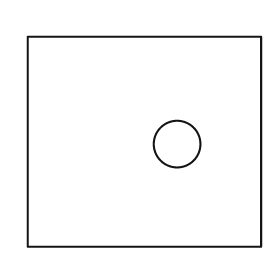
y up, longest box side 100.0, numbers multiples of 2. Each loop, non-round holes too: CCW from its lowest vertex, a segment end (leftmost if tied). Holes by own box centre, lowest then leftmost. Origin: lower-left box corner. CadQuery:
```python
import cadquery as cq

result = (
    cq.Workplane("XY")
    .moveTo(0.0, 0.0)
    .lineTo(100.0, 0.0)
    .lineTo(100.0, 90.0)
    .lineTo(0.0, 90.0)
    .close()
    .moveTo(64.0, 44.0)
    .circle(10.0)
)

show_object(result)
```